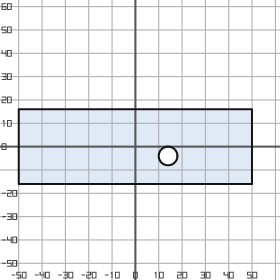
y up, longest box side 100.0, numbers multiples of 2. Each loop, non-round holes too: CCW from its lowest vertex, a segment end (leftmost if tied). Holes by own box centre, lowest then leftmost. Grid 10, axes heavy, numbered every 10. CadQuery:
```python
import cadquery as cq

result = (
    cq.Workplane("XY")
    .moveTo(-50.0, -16.0)
    .lineTo(50.0, -16.0)
    .lineTo(50.0, 16.0)
    .lineTo(-50.0, 16.0)
    .close()
    .moveTo(14.0, -4.0)
    .circle(4.0)
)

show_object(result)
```